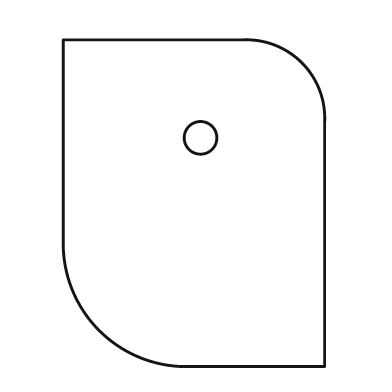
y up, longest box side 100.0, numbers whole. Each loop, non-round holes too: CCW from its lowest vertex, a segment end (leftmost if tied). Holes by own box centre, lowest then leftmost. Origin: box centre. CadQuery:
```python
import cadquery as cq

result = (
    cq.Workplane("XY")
    .moveTo(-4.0, -50.0)
    .lineTo(40.0, -50.0)
    .lineTo(40.0, 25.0)
    .threePointArc((33.0, 43.0), (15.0, 50.0))
    .lineTo(-40.0, 50.0)
    .lineTo(-40.0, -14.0)
    .threePointArc((-29.0, -39.0), (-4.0, -50.0))
    .close()
    .moveTo(2.0, 20.0)
    .circle(5.0)
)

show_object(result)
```